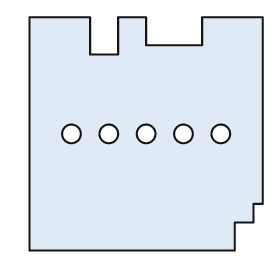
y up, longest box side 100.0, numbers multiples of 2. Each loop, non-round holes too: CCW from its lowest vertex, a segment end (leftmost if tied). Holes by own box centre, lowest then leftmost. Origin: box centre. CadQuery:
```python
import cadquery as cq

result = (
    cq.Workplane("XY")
    .moveTo(-50.0, -50.0)
    .lineTo(38.0, -50.0)
    .lineTo(38.0, -38.0)
    .lineTo(46.0, -38.0)
    .lineTo(46.0, -30.0)
    .lineTo(50.0, -30.0)
    .lineTo(50.0, 50.0)
    .lineTo(24.0, 50.0)
    .lineTo(24.0, 38.0)
    .lineTo(0.0, 38.0)
    .lineTo(0.0, 50.0)
    .lineTo(-12.0, 50.0)
    .lineTo(-12.0, 34.0)
    .lineTo(-24.0, 34.0)
    .lineTo(-24.0, 50.0)
    .lineTo(-50.0, 50.0)
    .close()
    .moveTo(-32.0, 0.0)
    .circle(4.0)
    .moveTo(-16.0, 0.0)
    .circle(4.0)
    .moveTo(0.0, 0.0)
    .circle(4.0)
    .moveTo(16.0, 0.0)
    .circle(4.0)
    .moveTo(32.0, 0.0)
    .circle(4.0)
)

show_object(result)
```